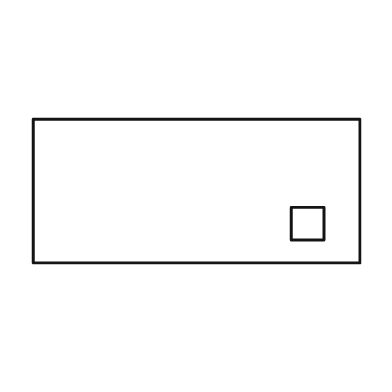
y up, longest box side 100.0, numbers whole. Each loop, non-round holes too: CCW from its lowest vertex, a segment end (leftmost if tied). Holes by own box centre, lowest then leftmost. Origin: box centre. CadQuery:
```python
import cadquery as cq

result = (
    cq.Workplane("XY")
    .moveTo(-50.0, -22.0)
    .lineTo(50.0, -22.0)
    .lineTo(50.0, 22.0)
    .lineTo(-50.0, 22.0)
    .close()
    .moveTo(29.0, -15.0)
    .lineTo(39.0, -15.0)
    .lineTo(39.0, -5.0)
    .lineTo(29.0, -5.0)
    .close()
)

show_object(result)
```